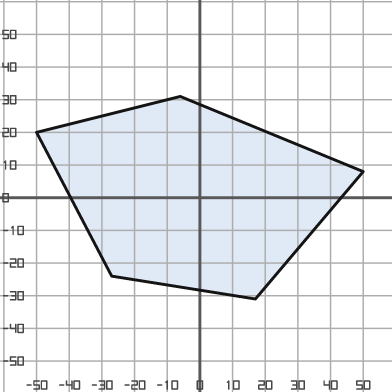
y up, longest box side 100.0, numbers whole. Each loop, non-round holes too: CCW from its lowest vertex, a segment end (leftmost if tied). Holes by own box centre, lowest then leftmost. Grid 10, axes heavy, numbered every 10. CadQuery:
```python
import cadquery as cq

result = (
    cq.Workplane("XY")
    .moveTo(17.0, -31.0)
    .lineTo(50.0, 8.0)
    .lineTo(-6.0, 31.0)
    .lineTo(-50.0, 20.0)
    .lineTo(-27.0, -24.0)
    .close()
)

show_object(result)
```